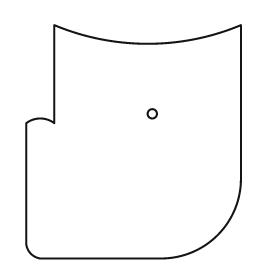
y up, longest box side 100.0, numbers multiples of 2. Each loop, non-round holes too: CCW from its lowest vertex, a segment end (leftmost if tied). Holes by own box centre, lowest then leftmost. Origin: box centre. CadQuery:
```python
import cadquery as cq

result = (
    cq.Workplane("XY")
    .moveTo(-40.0, -50.0)
    .lineTo(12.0, -50.0)
    .threePointArc((36.0, -40.0), (46.0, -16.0))
    .lineTo(46.0, 50.0)
    .threePointArc((6.0, 42.0), (-34.0, 50.0))
    .lineTo(-34.0, 8.0)
    .threePointArc((-40.0, 10.0), (-46.0, 8.0))
    .lineTo(-46.0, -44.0)
    .threePointArc((-44.0, -48.0), (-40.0, -50.0))
    .close()
    .moveTo(8.0, 12.0)
    .circle(2.0)
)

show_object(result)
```